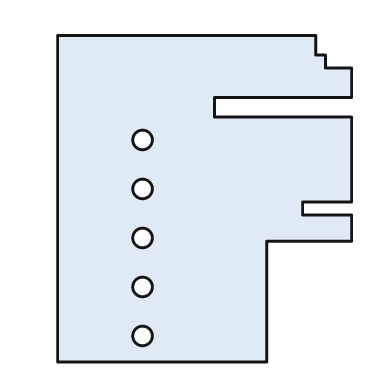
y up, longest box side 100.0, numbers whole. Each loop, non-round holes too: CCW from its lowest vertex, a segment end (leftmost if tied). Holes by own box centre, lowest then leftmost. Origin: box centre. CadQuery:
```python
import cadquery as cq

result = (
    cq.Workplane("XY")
    .moveTo(-45.0, -50.0)
    .lineTo(19.0, -50.0)
    .lineTo(19.0, -13.0)
    .lineTo(45.0, -13.0)
    .lineTo(45.0, -5.0)
    .lineTo(30.0, -5.0)
    .lineTo(30.0, -1.0)
    .lineTo(45.0, -1.0)
    .lineTo(45.0, 25.0)
    .lineTo(3.0, 25.0)
    .lineTo(3.0, 31.0)
    .lineTo(45.0, 31.0)
    .lineTo(45.0, 40.0)
    .lineTo(37.0, 40.0)
    .lineTo(37.0, 44.0)
    .lineTo(34.0, 44.0)
    .lineTo(34.0, 50.0)
    .lineTo(-45.0, 50.0)
    .close()
    .moveTo(-19.0, -42.0)
    .circle(3.0)
    .moveTo(-19.0, -27.0)
    .circle(3.0)
    .moveTo(-19.0, -12.0)
    .circle(3.0)
    .moveTo(-19.0, 3.0)
    .circle(3.0)
    .moveTo(-19.0, 18.0)
    .circle(3.0)
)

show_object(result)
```